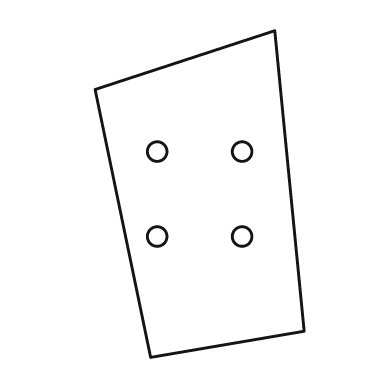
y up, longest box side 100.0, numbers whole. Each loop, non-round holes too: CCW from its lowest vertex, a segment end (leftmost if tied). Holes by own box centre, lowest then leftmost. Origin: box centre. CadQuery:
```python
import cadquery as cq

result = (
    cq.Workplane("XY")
    .moveTo(-15.0, -50.0)
    .lineTo(32.0, -42.0)
    .lineTo(23.0, 50.0)
    .lineTo(-32.0, 32.0)
    .close()
    .moveTo(-13.0, -13.0)
    .circle(3.0)
    .moveTo(13.0, -13.0)
    .circle(3.0)
    .moveTo(-13.0, 13.0)
    .circle(3.0)
    .moveTo(13.0, 13.0)
    .circle(3.0)
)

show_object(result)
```